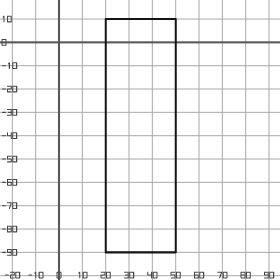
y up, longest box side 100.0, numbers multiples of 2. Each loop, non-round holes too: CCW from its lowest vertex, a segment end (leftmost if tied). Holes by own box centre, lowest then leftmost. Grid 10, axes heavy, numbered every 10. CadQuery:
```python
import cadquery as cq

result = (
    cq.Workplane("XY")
    .moveTo(20.0, -90.0)
    .lineTo(50.0, -90.0)
    .lineTo(50.0, 10.0)
    .lineTo(20.0, 10.0)
    .close()
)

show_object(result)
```